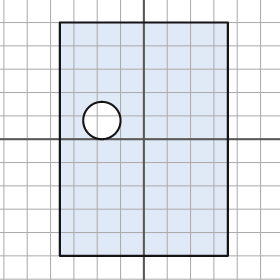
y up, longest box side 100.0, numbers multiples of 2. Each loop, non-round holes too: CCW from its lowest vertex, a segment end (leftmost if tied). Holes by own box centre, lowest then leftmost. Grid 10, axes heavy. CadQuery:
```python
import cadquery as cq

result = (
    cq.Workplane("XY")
    .moveTo(-36.0, -50.0)
    .lineTo(36.0, -50.0)
    .lineTo(36.0, 50.0)
    .lineTo(-36.0, 50.0)
    .close()
    .moveTo(-18.0, 8.0)
    .circle(8.0)
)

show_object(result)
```